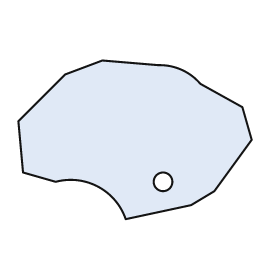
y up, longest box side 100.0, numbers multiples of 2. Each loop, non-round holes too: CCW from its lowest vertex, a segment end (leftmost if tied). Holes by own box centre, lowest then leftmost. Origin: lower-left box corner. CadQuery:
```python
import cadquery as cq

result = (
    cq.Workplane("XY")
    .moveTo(46.0, 0.0)
    .lineTo(74.0, 6.0)
    .lineTo(84.0, 12.0)
    .lineTo(100.0, 34.0)
    .lineTo(96.0, 48.0)
    .lineTo(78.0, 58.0)
    .threePointArc((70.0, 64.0), (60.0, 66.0))
    .lineTo(36.0, 68.0)
    .lineTo(20.0, 62.0)
    .lineTo(0.0, 42.0)
    .lineTo(2.0, 20.0)
    .lineTo(16.0, 16.0)
    .threePointArc((34.0, 14.0), (46.0, 0.0))
    .close()
    .moveTo(62.0, 16.0)
    .circle(4.0)
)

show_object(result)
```